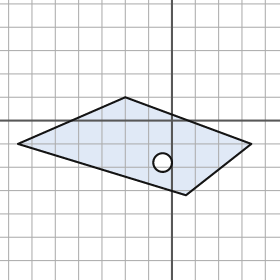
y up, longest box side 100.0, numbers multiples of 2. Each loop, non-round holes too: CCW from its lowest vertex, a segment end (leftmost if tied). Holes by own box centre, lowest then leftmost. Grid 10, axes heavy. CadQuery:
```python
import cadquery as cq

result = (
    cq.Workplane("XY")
    .moveTo(6.0, -32.0)
    .lineTo(34.0, -10.0)
    .lineTo(-20.0, 10.0)
    .lineTo(-66.0, -10.0)
    .close()
    .moveTo(-4.0, -18.0)
    .circle(4.0)
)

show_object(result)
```